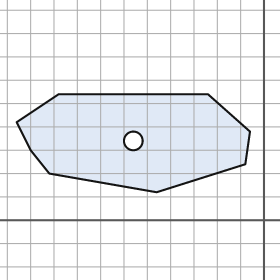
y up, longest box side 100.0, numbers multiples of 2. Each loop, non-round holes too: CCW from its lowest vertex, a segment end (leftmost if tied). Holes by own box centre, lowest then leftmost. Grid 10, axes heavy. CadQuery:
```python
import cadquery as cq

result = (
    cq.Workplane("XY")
    .moveTo(-46.0, 12.0)
    .lineTo(-8.0, 24.0)
    .lineTo(-6.0, 38.0)
    .lineTo(-24.0, 54.0)
    .lineTo(-88.0, 54.0)
    .lineTo(-106.0, 42.0)
    .lineTo(-100.0, 30.0)
    .lineTo(-92.0, 20.0)
    .close()
    .moveTo(-56.0, 34.0)
    .circle(4.0)
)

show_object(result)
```